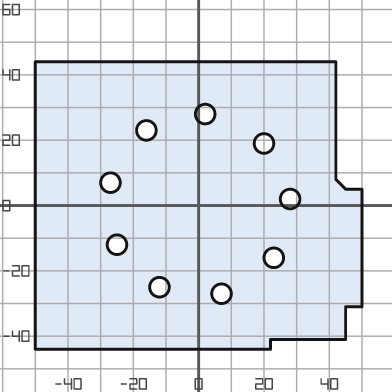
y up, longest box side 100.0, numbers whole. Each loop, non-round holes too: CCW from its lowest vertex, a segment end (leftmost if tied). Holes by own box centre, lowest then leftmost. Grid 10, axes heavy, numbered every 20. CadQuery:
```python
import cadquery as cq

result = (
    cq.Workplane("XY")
    .moveTo(-50.0, -44.0)
    .lineTo(22.0, -44.0)
    .lineTo(22.0, -41.0)
    .lineTo(45.0, -41.0)
    .lineTo(45.0, -31.0)
    .lineTo(50.0, -31.0)
    .lineTo(50.0, 5.0)
    .lineTo(45.0, 5.0)
    .lineTo(42.0, 8.0)
    .lineTo(42.0, 44.0)
    .lineTo(-50.0, 44.0)
    .close()
    .moveTo(7.0, -27.0)
    .circle(3.0)
    .moveTo(-12.0, -25.0)
    .circle(3.0)
    .moveTo(23.0, -16.0)
    .circle(3.0)
    .moveTo(-25.0, -12.0)
    .circle(3.0)
    .moveTo(28.0, 2.0)
    .circle(3.0)
    .moveTo(-27.0, 7.0)
    .circle(3.0)
    .moveTo(20.0, 19.0)
    .circle(3.0)
    .moveTo(-16.0, 23.0)
    .circle(3.0)
    .moveTo(2.0, 28.0)
    .circle(3.0)
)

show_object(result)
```